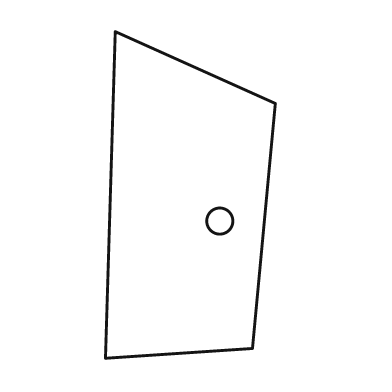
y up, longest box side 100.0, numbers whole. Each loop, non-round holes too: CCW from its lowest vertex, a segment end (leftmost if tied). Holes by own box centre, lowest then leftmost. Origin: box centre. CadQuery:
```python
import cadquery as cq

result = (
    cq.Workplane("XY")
    .moveTo(-26.0, -50.0)
    .lineTo(19.0, -47.0)
    .lineTo(26.0, 28.0)
    .lineTo(-23.0, 50.0)
    .close()
    .moveTo(9.0, -8.0)
    .circle(4.0)
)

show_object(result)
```